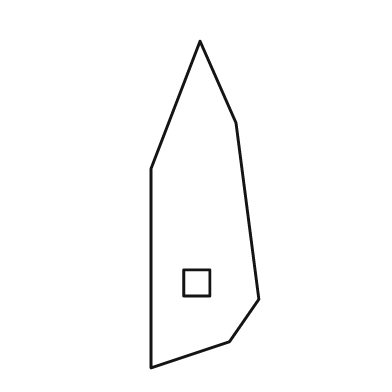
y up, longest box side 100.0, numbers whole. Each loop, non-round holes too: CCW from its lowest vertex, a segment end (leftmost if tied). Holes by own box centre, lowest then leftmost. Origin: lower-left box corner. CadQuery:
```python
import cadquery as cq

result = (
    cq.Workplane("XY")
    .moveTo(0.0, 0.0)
    .lineTo(24.0, 8.0)
    .lineTo(33.0, 21.0)
    .lineTo(26.0, 75.0)
    .lineTo(15.0, 100.0)
    .lineTo(0.0, 61.0)
    .close()
    .moveTo(10.0, 22.0)
    .lineTo(18.0, 22.0)
    .lineTo(18.0, 30.0)
    .lineTo(10.0, 30.0)
    .close()
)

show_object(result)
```